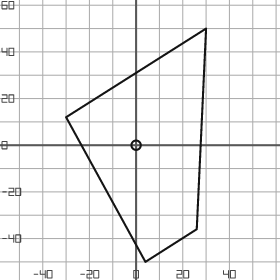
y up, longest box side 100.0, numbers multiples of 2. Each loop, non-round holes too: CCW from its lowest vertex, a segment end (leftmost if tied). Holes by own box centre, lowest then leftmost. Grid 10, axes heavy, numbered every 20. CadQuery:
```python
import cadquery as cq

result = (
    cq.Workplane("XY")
    .moveTo(4.0, -50.0)
    .lineTo(26.0, -36.0)
    .lineTo(30.0, 50.0)
    .lineTo(-30.0, 12.0)
    .close()
    .moveTo(0.0, 0.0)
    .circle(2.0)
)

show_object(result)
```